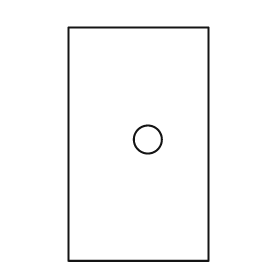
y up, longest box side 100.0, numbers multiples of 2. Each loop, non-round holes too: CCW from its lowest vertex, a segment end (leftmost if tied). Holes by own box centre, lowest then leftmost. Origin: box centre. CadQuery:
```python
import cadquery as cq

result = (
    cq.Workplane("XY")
    .moveTo(-30.0, -50.0)
    .lineTo(30.0, -50.0)
    .lineTo(30.0, 50.0)
    .lineTo(-30.0, 50.0)
    .close()
    .moveTo(4.0, 2.0)
    .circle(6.0)
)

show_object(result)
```